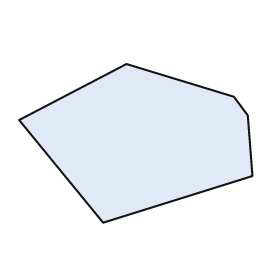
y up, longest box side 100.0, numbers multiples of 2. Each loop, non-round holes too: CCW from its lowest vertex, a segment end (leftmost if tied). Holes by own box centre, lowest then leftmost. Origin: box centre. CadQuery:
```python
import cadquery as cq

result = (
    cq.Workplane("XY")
    .moveTo(-14.0, -34.0)
    .lineTo(50.0, -14.0)
    .lineTo(48.0, 12.0)
    .lineTo(42.0, 20.0)
    .lineTo(-4.0, 34.0)
    .lineTo(-50.0, 10.0)
    .close()
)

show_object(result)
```